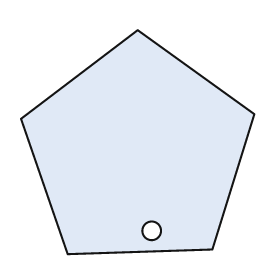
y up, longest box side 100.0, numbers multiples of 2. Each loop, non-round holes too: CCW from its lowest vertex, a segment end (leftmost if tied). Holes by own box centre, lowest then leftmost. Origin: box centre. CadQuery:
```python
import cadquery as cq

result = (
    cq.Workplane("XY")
    .moveTo(-30.0, -48.0)
    .lineTo(32.0, -46.0)
    .lineTo(50.0, 12.0)
    .lineTo(0.0, 48.0)
    .lineTo(-50.0, 10.0)
    .close()
    .moveTo(6.0, -38.0)
    .circle(4.0)
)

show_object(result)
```